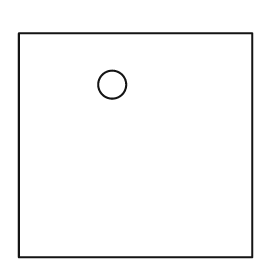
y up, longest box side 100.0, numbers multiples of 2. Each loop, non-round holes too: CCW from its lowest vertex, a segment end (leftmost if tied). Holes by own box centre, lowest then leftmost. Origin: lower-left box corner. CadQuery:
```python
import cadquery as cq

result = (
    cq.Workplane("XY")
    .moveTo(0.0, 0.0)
    .lineTo(100.0, 0.0)
    .lineTo(100.0, 96.0)
    .lineTo(0.0, 96.0)
    .close()
    .moveTo(40.0, 74.0)
    .circle(6.0)
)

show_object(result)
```